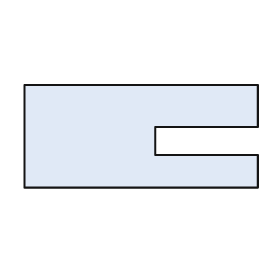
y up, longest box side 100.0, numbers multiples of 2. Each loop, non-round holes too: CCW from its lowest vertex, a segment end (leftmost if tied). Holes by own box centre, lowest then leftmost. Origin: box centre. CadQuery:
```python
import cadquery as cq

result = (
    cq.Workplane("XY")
    .moveTo(-50.0, -22.0)
    .lineTo(50.0, -22.0)
    .lineTo(50.0, -8.0)
    .lineTo(6.0, -8.0)
    .lineTo(6.0, 4.0)
    .lineTo(50.0, 4.0)
    .lineTo(50.0, 22.0)
    .lineTo(-50.0, 22.0)
    .close()
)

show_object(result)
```